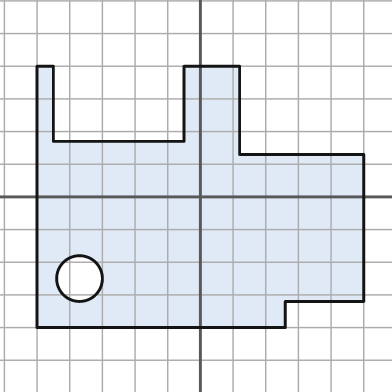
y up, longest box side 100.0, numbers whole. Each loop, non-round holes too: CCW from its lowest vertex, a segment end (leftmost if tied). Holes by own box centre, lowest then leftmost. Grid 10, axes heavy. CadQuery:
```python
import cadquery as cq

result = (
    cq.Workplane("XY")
    .moveTo(-50.0, -40.0)
    .lineTo(26.0, -40.0)
    .lineTo(26.0, -32.0)
    .lineTo(50.0, -32.0)
    .lineTo(50.0, 13.0)
    .lineTo(12.0, 13.0)
    .lineTo(12.0, 40.0)
    .lineTo(-5.0, 40.0)
    .lineTo(-5.0, 17.0)
    .lineTo(-45.0, 17.0)
    .lineTo(-45.0, 40.0)
    .lineTo(-50.0, 40.0)
    .close()
    .moveTo(-37.0, -25.0)
    .circle(7.0)
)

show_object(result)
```